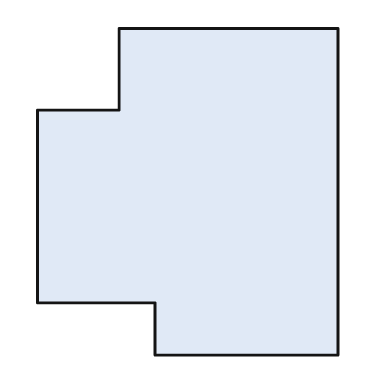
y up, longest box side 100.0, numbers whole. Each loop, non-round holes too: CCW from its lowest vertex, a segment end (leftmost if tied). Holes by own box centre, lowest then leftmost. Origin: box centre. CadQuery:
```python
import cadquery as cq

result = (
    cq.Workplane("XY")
    .moveTo(-10.0, -50.0)
    .lineTo(46.0, -50.0)
    .lineTo(46.0, 50.0)
    .lineTo(-21.0, 50.0)
    .lineTo(-21.0, 25.0)
    .lineTo(-46.0, 25.0)
    .lineTo(-46.0, -34.0)
    .lineTo(-10.0, -34.0)
    .close()
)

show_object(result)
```